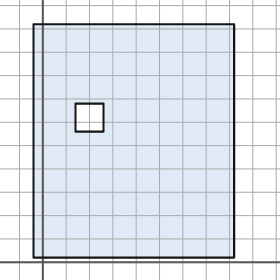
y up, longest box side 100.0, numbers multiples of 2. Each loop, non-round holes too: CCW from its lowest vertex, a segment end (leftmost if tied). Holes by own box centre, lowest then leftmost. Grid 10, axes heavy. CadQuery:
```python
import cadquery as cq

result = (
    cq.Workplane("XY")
    .moveTo(-4.0, 2.0)
    .lineTo(82.0, 2.0)
    .lineTo(82.0, 102.0)
    .lineTo(-4.0, 102.0)
    .close()
    .moveTo(14.0, 56.0)
    .lineTo(26.0, 56.0)
    .lineTo(26.0, 68.0)
    .lineTo(14.0, 68.0)
    .close()
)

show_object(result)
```